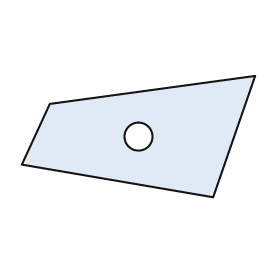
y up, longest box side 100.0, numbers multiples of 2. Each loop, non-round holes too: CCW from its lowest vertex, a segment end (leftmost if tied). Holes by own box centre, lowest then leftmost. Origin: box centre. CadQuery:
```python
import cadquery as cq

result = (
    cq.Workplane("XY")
    .moveTo(32.0, -26.0)
    .lineTo(50.0, 26.0)
    .lineTo(-38.0, 14.0)
    .lineTo(-50.0, -12.0)
    .close()
    .moveTo(0.0, 0.0)
    .circle(6.0)
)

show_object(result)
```